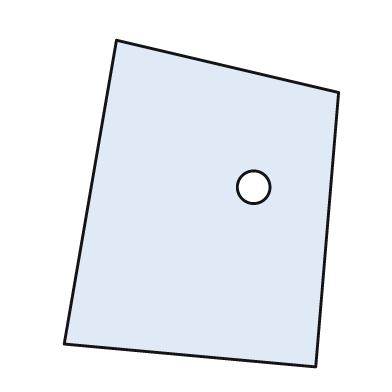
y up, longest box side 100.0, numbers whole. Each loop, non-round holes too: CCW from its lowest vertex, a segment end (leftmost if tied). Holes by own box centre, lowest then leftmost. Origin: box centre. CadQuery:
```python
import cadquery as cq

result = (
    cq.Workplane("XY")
    .moveTo(35.0, -50.0)
    .lineTo(42.0, 34.0)
    .lineTo(-26.0, 50.0)
    .lineTo(-42.0, -43.0)
    .close()
    .moveTo(16.0, 5.0)
    .circle(5.0)
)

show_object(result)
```